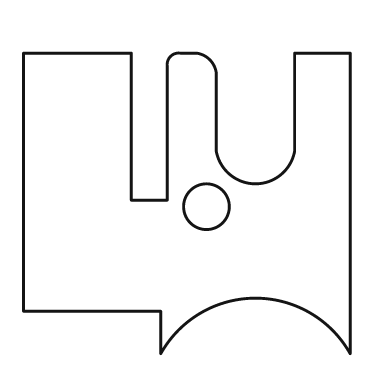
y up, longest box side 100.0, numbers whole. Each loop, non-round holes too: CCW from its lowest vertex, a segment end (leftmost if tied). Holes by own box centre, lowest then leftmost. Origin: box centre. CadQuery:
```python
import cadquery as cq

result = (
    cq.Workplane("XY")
    .moveTo(-8.0, -46.0)
    .threePointArc((21.0, -29.0), (50.0, -46.0))
    .lineTo(50.0, 46.0)
    .lineTo(33.0, 46.0)
    .lineTo(33.0, 16.0)
    .threePointArc((21.0, 6.0), (9.0, 16.0))
    .lineTo(9.0, 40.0)
    .threePointArc((7.0, 44.0), (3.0, 46.0))
    .lineTo(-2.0, 46.0)
    .threePointArc((-5.0, 45.0), (-6.0, 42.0))
    .lineTo(-6.0, 1.0)
    .lineTo(-17.0, 1.0)
    .lineTo(-17.0, 46.0)
    .lineTo(-50.0, 46.0)
    .lineTo(-50.0, -33.0)
    .lineTo(-8.0, -33.0)
    .close()
    .moveTo(6.0, -1.0)
    .circle(7.0)
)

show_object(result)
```